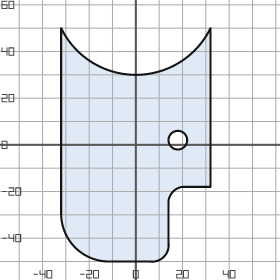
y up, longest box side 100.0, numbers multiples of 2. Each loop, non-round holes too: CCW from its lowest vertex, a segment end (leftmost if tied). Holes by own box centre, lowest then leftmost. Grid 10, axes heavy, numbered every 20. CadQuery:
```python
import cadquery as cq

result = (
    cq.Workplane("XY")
    .moveTo(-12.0, -50.0)
    .lineTo(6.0, -50.0)
    .threePointArc((12.0, -48.0), (14.0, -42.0))
    .lineTo(14.0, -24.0)
    .threePointArc((16.0, -20.0), (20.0, -18.0))
    .lineTo(32.0, -18.0)
    .lineTo(32.0, 50.0)
    .threePointArc((0.0, 30.0), (-32.0, 50.0))
    .lineTo(-32.0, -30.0)
    .threePointArc((-26.0, -44.0), (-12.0, -50.0))
    .close()
    .moveTo(18.0, 2.0)
    .circle(4.0)
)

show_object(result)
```